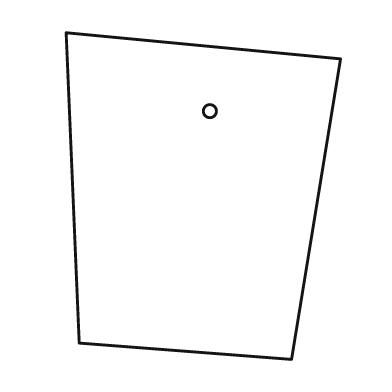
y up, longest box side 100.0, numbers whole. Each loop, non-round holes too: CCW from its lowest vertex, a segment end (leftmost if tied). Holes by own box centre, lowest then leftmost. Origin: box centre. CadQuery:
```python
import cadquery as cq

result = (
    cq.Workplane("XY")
    .moveTo(27.0, -50.0)
    .lineTo(42.0, 42.0)
    .lineTo(-42.0, 50.0)
    .lineTo(-38.0, -45.0)
    .close()
    .moveTo(2.0, 26.0)
    .circle(2.0)
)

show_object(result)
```